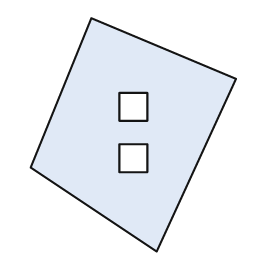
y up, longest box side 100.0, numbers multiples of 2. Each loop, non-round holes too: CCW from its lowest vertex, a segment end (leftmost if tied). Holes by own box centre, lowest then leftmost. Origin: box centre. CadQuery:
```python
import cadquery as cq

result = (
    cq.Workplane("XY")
    .moveTo(10.0, -50.0)
    .lineTo(44.0, 24.0)
    .lineTo(-18.0, 50.0)
    .lineTo(-44.0, -14.0)
    .close()
    .moveTo(-6.0, -16.0)
    .lineTo(6.0, -16.0)
    .lineTo(6.0, -4.0)
    .lineTo(-6.0, -4.0)
    .close()
    .moveTo(-6.0, 6.0)
    .lineTo(6.0, 6.0)
    .lineTo(6.0, 18.0)
    .lineTo(-6.0, 18.0)
    .close()
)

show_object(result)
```